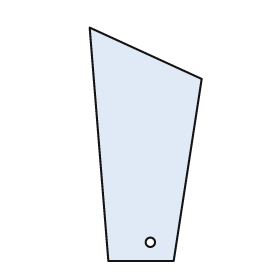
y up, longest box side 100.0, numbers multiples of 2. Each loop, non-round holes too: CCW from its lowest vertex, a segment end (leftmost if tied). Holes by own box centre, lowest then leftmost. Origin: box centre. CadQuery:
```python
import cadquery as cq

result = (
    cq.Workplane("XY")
    .moveTo(-16.0, -50.0)
    .lineTo(12.0, -50.0)
    .lineTo(24.0, 28.0)
    .lineTo(-24.0, 50.0)
    .close()
    .moveTo(2.0, -42.0)
    .circle(2.0)
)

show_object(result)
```